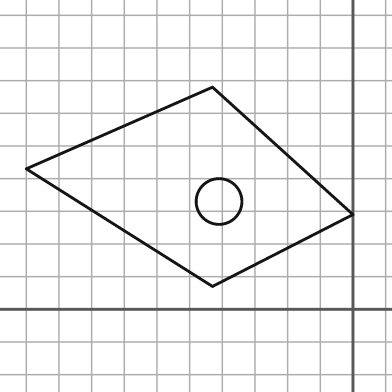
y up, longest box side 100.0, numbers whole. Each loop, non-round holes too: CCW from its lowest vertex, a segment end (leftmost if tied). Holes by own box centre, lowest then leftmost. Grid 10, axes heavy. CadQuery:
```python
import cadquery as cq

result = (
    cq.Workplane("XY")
    .moveTo(-43.0, 7.0)
    .lineTo(0.0, 29.0)
    .lineTo(-43.0, 68.0)
    .lineTo(-100.0, 43.0)
    .close()
    .moveTo(-41.0, 33.0)
    .circle(7.0)
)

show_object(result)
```